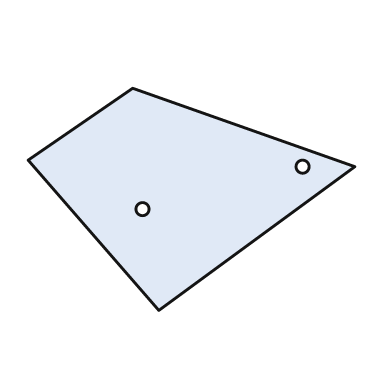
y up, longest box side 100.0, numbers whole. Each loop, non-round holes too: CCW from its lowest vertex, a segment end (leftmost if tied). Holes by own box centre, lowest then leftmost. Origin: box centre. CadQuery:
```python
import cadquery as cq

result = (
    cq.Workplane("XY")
    .moveTo(-10.0, -34.0)
    .lineTo(50.0, 10.0)
    .lineTo(-18.0, 34.0)
    .lineTo(-50.0, 12.0)
    .close()
    .moveTo(-15.0, -3.0)
    .circle(2.0)
    .moveTo(34.0, 10.0)
    .circle(2.0)
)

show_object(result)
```